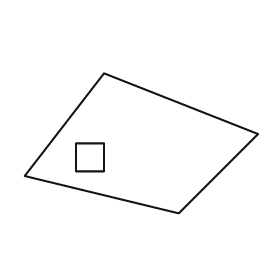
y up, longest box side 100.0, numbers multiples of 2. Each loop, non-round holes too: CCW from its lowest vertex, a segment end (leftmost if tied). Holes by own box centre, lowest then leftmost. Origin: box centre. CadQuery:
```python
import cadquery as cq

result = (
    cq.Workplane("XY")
    .moveTo(16.0, -30.0)
    .lineTo(50.0, 4.0)
    .lineTo(-16.0, 30.0)
    .lineTo(-50.0, -14.0)
    .close()
    .moveTo(-28.0, -12.0)
    .lineTo(-16.0, -12.0)
    .lineTo(-16.0, 0.0)
    .lineTo(-28.0, 0.0)
    .close()
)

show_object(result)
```